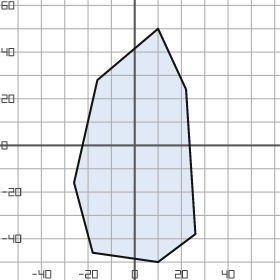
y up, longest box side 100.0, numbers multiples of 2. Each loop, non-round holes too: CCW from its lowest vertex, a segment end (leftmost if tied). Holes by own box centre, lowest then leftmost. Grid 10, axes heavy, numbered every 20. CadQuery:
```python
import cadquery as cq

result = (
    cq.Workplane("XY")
    .moveTo(10.0, -50.0)
    .lineTo(26.0, -38.0)
    .lineTo(22.0, 24.0)
    .lineTo(10.0, 50.0)
    .lineTo(-16.0, 28.0)
    .lineTo(-26.0, -16.0)
    .lineTo(-18.0, -46.0)
    .close()
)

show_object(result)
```